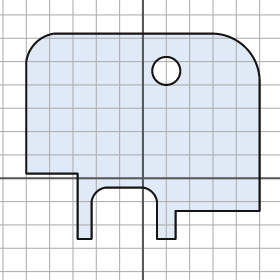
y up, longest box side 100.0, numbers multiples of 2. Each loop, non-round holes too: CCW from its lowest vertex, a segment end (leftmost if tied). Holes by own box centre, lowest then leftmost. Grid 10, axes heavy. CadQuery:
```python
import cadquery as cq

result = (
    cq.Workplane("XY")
    .moveTo(-28.0, -26.0)
    .lineTo(-22.0, -26.0)
    .lineTo(-22.0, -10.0)
    .threePointArc((-20.0, -6.0), (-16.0, -4.0))
    .lineTo(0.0, -4.0)
    .threePointArc((4.0, -6.0), (6.0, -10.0))
    .lineTo(6.0, -26.0)
    .lineTo(14.0, -26.0)
    .lineTo(14.0, -14.0)
    .lineTo(50.0, -14.0)
    .lineTo(50.0, 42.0)
    .threePointArc((44.0, 56.0), (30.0, 62.0))
    .lineTo(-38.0, 62.0)
    .threePointArc((-46.0, 58.0), (-50.0, 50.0))
    .lineTo(-50.0, 2.0)
    .lineTo(-28.0, 2.0)
    .close()
    .moveTo(10.0, 46.0)
    .circle(6.0)
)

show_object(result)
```